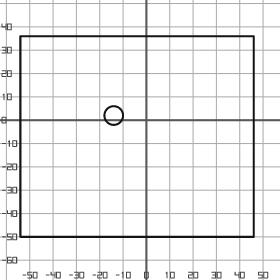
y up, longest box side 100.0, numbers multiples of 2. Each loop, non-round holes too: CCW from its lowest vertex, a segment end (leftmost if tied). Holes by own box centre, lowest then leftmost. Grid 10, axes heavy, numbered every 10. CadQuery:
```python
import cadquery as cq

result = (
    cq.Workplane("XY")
    .moveTo(-54.0, -50.0)
    .lineTo(46.0, -50.0)
    .lineTo(46.0, 36.0)
    .lineTo(-54.0, 36.0)
    .close()
    .moveTo(-14.0, 2.0)
    .circle(4.0)
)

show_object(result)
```